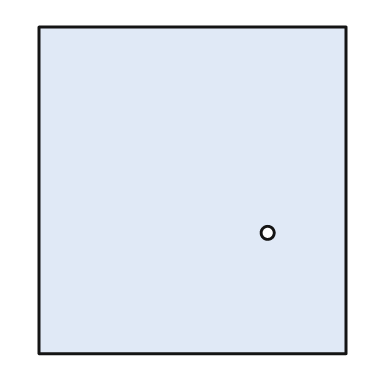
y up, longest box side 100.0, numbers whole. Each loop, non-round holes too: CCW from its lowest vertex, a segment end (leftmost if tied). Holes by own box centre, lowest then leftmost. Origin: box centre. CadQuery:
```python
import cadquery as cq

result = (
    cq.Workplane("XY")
    .moveTo(-47.0, -50.0)
    .lineTo(47.0, -50.0)
    .lineTo(47.0, 50.0)
    .lineTo(-47.0, 50.0)
    .close()
    .moveTo(23.0, -13.0)
    .circle(2.0)
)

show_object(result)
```